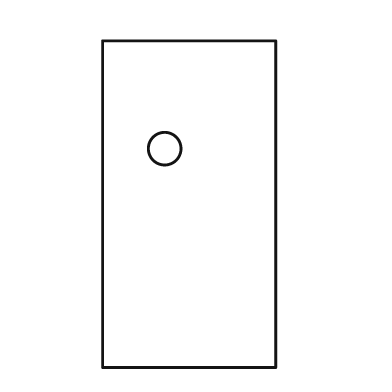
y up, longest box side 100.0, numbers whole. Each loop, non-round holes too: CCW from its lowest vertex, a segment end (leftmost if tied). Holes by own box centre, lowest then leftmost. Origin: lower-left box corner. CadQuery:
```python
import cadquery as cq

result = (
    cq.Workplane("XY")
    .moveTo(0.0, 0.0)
    .lineTo(53.0, 0.0)
    .lineTo(53.0, 100.0)
    .lineTo(0.0, 100.0)
    .close()
    .moveTo(19.0, 67.0)
    .circle(5.0)
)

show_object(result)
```